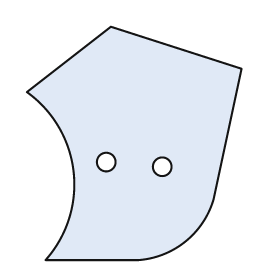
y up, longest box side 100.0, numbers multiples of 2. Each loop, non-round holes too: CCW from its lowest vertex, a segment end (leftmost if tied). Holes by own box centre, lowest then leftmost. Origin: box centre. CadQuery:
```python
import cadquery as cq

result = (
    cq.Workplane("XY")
    .moveTo(-38.0, -50.0)
    .lineTo(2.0, -50.0)
    .threePointArc((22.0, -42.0), (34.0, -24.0))
    .lineTo(46.0, 32.0)
    .lineTo(-10.0, 50.0)
    .lineTo(-46.0, 22.0)
    .threePointArc((-26.0, -12.0), (-38.0, -50.0))
    .close()
    .moveTo(12.0, -10.0)
    .circle(4.0)
    .moveTo(-12.0, -8.0)
    .circle(4.0)
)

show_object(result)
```